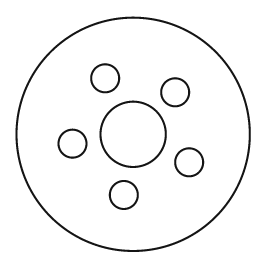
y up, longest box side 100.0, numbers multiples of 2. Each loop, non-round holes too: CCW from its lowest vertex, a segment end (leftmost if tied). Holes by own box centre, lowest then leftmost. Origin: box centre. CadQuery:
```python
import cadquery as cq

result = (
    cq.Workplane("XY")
    .moveTo(0.0, 0.0)
    .circle(50.0)
    .moveTo(-4.0, -26.0)
    .circle(6.0)
    .moveTo(24.0, -12.0)
    .circle(6.0)
    .moveTo(-26.0, -4.0)
    .circle(6.0)
    .moveTo(0.0, 0.0)
    .circle(14.0)
    .moveTo(18.0, 18.0)
    .circle(6.0)
    .moveTo(-12.0, 24.0)
    .circle(6.0)
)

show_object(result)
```